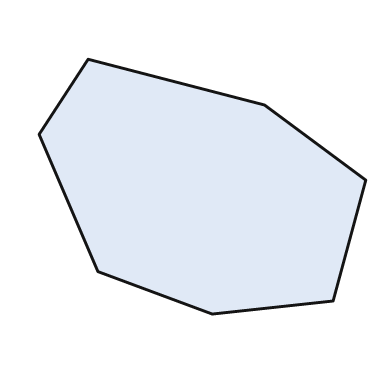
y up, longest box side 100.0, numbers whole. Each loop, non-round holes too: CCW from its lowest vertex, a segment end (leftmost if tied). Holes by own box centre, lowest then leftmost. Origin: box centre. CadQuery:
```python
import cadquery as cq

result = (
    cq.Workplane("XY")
    .moveTo(3.0, -39.0)
    .lineTo(40.0, -35.0)
    .lineTo(50.0, 2.0)
    .lineTo(19.0, 25.0)
    .lineTo(-35.0, 39.0)
    .lineTo(-50.0, 16.0)
    .lineTo(-32.0, -26.0)
    .close()
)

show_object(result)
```